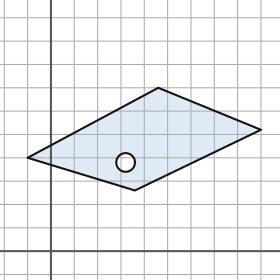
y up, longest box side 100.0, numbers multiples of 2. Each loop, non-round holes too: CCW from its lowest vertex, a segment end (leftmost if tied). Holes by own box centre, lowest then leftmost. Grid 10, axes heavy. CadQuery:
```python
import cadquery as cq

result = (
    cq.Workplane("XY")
    .moveTo(36.0, 26.0)
    .lineTo(90.0, 52.0)
    .lineTo(46.0, 70.0)
    .lineTo(-10.0, 40.0)
    .close()
    .moveTo(32.0, 38.0)
    .circle(4.0)
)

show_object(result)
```